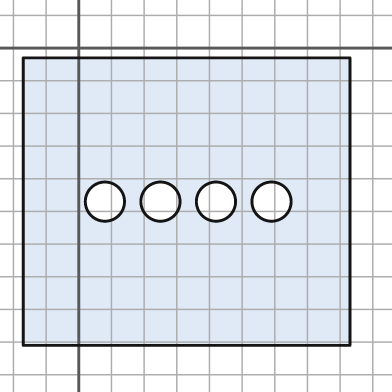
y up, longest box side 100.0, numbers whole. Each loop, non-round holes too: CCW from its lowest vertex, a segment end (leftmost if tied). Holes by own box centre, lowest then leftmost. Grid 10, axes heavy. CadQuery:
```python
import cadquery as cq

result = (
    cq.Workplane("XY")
    .moveTo(-17.0, -91.0)
    .lineTo(83.0, -91.0)
    .lineTo(83.0, -3.0)
    .lineTo(-17.0, -3.0)
    .close()
    .moveTo(8.0, -47.0)
    .circle(6.0)
    .moveTo(25.0, -47.0)
    .circle(6.0)
    .moveTo(42.0, -47.0)
    .circle(6.0)
    .moveTo(59.0, -47.0)
    .circle(6.0)
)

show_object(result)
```